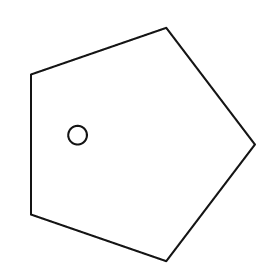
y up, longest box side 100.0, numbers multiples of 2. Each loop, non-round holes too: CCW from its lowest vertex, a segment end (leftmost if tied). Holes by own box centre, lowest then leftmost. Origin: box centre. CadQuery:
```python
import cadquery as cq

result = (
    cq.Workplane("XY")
    .moveTo(10.0, -50.0)
    .lineTo(48.0, 0.0)
    .lineTo(10.0, 50.0)
    .lineTo(-48.0, 30.0)
    .lineTo(-48.0, -30.0)
    .close()
    .moveTo(-28.0, 4.0)
    .circle(4.0)
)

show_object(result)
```